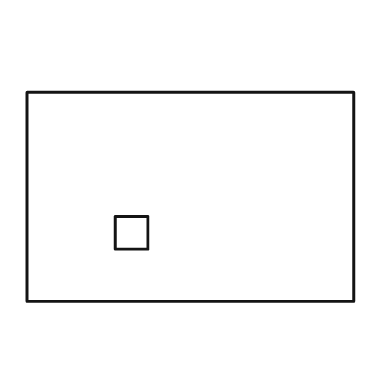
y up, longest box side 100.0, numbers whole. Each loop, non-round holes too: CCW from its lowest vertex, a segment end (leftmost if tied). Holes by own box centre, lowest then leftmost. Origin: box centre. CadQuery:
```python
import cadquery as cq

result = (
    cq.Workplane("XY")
    .moveTo(-50.0, -32.0)
    .lineTo(50.0, -32.0)
    .lineTo(50.0, 32.0)
    .lineTo(-50.0, 32.0)
    .close()
    .moveTo(-23.0, -16.0)
    .lineTo(-13.0, -16.0)
    .lineTo(-13.0, -6.0)
    .lineTo(-23.0, -6.0)
    .close()
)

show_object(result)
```